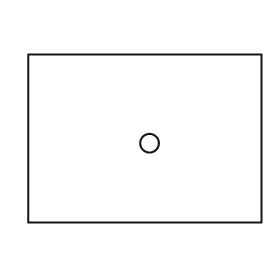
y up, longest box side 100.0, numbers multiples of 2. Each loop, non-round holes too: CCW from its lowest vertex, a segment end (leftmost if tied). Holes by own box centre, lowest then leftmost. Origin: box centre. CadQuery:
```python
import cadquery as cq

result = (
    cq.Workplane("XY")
    .moveTo(-50.0, -36.0)
    .lineTo(50.0, -36.0)
    .lineTo(50.0, 36.0)
    .lineTo(-50.0, 36.0)
    .close()
    .moveTo(2.0, -2.0)
    .circle(4.0)
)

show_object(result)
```